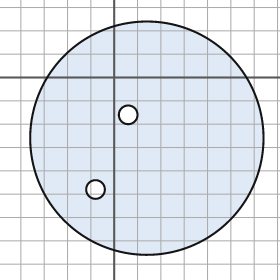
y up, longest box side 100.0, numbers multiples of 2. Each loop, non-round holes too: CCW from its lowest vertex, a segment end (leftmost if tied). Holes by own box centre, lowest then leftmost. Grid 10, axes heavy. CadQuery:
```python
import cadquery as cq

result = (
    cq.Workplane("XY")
    .moveTo(14.0, -26.0)
    .circle(50.0)
    .moveTo(-8.0, -48.0)
    .circle(4.0)
    .moveTo(6.0, -16.0)
    .circle(4.0)
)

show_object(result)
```